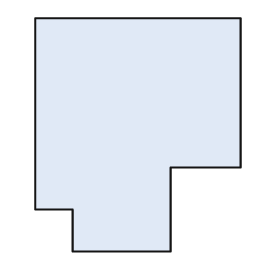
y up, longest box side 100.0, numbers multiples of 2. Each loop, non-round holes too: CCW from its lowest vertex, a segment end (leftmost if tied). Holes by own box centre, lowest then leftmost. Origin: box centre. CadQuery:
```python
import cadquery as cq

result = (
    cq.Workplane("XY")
    .moveTo(-28.0, -50.0)
    .lineTo(14.0, -50.0)
    .lineTo(14.0, -14.0)
    .lineTo(44.0, -14.0)
    .lineTo(44.0, 50.0)
    .lineTo(-44.0, 50.0)
    .lineTo(-44.0, -32.0)
    .lineTo(-28.0, -32.0)
    .close()
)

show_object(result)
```